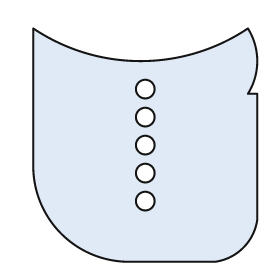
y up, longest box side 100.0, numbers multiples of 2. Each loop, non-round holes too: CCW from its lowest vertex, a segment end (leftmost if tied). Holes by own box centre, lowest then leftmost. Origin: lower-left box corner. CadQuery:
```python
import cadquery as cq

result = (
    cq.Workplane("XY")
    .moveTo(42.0, 0.0)
    .lineTo(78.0, 0.0)
    .threePointArc((90.0, 6.0), (96.0, 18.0))
    .lineTo(96.0, 72.0)
    .lineTo(92.0, 72.0)
    .threePointArc((96.0, 86.0), (92.0, 100.0))
    .threePointArc((46.0, 86.0), (0.0, 100.0))
    .lineTo(0.0, 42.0)
    .threePointArc((12.0, 12.0), (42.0, 0.0))
    .close()
    .moveTo(48.0, 26.0)
    .circle(4.0)
    .moveTo(48.0, 38.0)
    .circle(4.0)
    .moveTo(48.0, 50.0)
    .circle(4.0)
    .moveTo(48.0, 62.0)
    .circle(4.0)
    .moveTo(48.0, 74.0)
    .circle(4.0)
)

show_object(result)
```